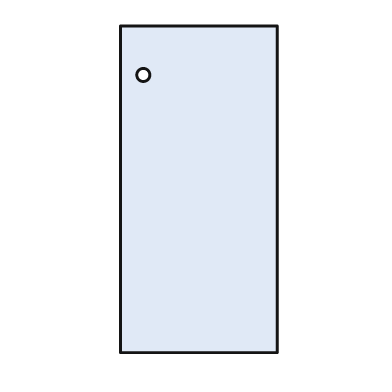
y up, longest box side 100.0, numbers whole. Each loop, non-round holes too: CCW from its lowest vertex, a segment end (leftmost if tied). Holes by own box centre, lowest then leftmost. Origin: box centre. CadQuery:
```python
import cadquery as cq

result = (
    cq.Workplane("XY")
    .moveTo(-24.0, -50.0)
    .lineTo(24.0, -50.0)
    .lineTo(24.0, 50.0)
    .lineTo(-24.0, 50.0)
    .close()
    .moveTo(-17.0, 35.0)
    .circle(2.0)
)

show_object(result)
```